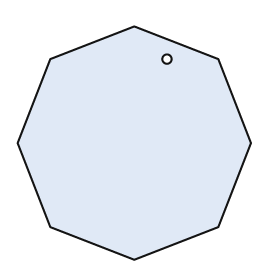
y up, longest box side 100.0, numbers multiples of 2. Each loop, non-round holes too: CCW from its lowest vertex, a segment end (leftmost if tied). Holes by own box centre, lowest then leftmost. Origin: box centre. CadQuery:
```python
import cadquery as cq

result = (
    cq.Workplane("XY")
    .moveTo(0.0, -50.0)
    .lineTo(36.0, -36.0)
    .lineTo(50.0, 0.0)
    .lineTo(36.0, 36.0)
    .lineTo(0.0, 50.0)
    .lineTo(-36.0, 36.0)
    .lineTo(-50.0, 0.0)
    .lineTo(-36.0, -36.0)
    .close()
    .moveTo(14.0, 36.0)
    .circle(2.0)
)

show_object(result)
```